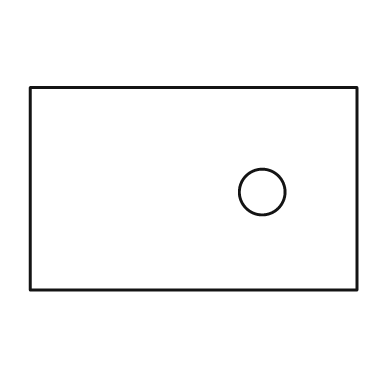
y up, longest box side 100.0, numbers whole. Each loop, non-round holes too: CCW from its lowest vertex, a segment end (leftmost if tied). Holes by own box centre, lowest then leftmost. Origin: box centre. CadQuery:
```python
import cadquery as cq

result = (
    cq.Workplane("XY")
    .moveTo(-50.0, -31.0)
    .lineTo(50.0, -31.0)
    .lineTo(50.0, 31.0)
    .lineTo(-50.0, 31.0)
    .close()
    .moveTo(21.0, -1.0)
    .circle(7.0)
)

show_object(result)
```